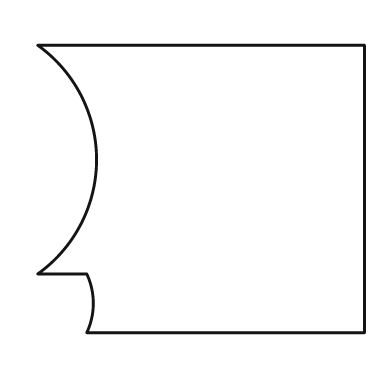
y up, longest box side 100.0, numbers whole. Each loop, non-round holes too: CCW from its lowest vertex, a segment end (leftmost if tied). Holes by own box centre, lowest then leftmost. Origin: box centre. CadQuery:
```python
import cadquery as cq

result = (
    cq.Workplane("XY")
    .moveTo(-35.0, -44.0)
    .lineTo(50.0, -44.0)
    .lineTo(50.0, 44.0)
    .lineTo(-50.0, 44.0)
    .threePointArc((-32.0, 9.0), (-50.0, -26.0))
    .lineTo(-35.0, -26.0)
    .threePointArc((-33.0, -35.0), (-35.0, -44.0))
    .close()
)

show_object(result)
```